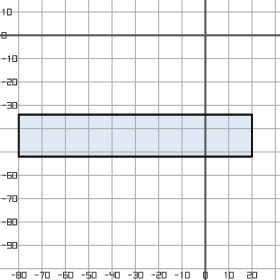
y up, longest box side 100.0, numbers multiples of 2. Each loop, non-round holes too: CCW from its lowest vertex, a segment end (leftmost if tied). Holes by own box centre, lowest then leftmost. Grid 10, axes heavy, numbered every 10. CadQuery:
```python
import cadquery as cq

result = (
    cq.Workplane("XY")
    .moveTo(-80.0, -52.0)
    .lineTo(20.0, -52.0)
    .lineTo(20.0, -34.0)
    .lineTo(-80.0, -34.0)
    .close()
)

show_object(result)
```